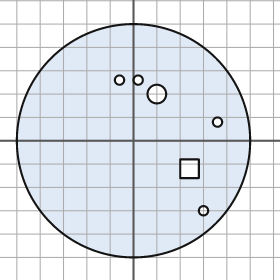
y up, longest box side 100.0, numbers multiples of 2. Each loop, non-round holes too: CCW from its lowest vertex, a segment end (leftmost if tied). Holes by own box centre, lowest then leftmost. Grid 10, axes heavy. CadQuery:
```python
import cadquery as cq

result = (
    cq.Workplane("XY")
    .moveTo(0.0, 0.0)
    .circle(50.0)
    .moveTo(30.0, -30.0)
    .circle(2.0)
    .moveTo(20.0, -16.0)
    .lineTo(28.0, -16.0)
    .lineTo(28.0, -8.0)
    .lineTo(20.0, -8.0)
    .close()
    .moveTo(36.0, 8.0)
    .circle(2.0)
    .moveTo(10.0, 20.0)
    .circle(4.0)
    .moveTo(-6.0, 26.0)
    .circle(2.0)
    .moveTo(2.0, 26.0)
    .circle(2.0)
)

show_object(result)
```